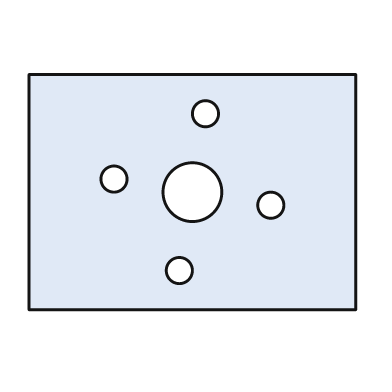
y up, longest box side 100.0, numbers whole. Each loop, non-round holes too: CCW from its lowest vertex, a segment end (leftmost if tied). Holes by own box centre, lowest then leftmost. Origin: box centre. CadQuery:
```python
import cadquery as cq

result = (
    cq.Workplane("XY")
    .moveTo(-50.0, -36.0)
    .lineTo(50.0, -36.0)
    .lineTo(50.0, 36.0)
    .lineTo(-50.0, 36.0)
    .close()
    .moveTo(-4.0, -24.0)
    .circle(4.0)
    .moveTo(24.0, -4.0)
    .circle(4.0)
    .moveTo(0.0, 0.0)
    .circle(9.0)
    .moveTo(-24.0, 4.0)
    .circle(4.0)
    .moveTo(4.0, 24.0)
    .circle(4.0)
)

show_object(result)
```